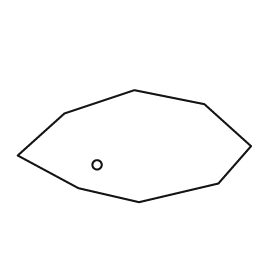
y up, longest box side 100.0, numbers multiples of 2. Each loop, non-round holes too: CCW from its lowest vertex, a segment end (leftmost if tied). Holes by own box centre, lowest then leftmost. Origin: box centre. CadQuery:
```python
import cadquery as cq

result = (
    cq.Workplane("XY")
    .moveTo(2.0, -24.0)
    .lineTo(36.0, -16.0)
    .lineTo(50.0, 0.0)
    .lineTo(30.0, 18.0)
    .lineTo(0.0, 24.0)
    .lineTo(-30.0, 14.0)
    .lineTo(-50.0, -4.0)
    .lineTo(-24.0, -18.0)
    .close()
    .moveTo(-16.0, -8.0)
    .circle(2.0)
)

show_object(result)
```